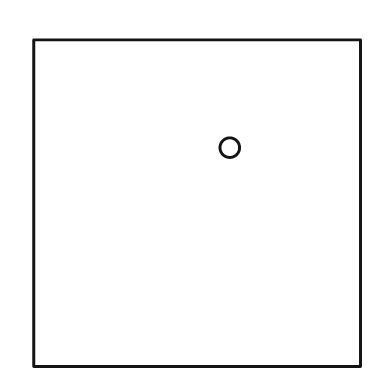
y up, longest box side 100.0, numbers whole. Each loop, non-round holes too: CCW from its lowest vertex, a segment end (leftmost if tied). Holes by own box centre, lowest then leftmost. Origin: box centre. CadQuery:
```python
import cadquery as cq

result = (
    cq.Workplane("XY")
    .moveTo(-50.0, -50.0)
    .lineTo(50.0, -50.0)
    .lineTo(50.0, 50.0)
    .lineTo(-50.0, 50.0)
    .close()
    .moveTo(10.0, 17.0)
    .circle(3.0)
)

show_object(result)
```